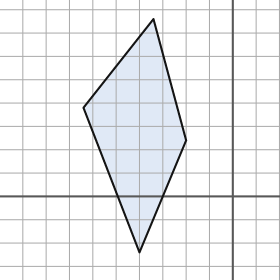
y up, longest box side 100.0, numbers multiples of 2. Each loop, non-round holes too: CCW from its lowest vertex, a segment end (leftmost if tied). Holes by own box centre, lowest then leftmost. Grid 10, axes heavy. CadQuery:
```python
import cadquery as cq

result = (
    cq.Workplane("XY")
    .moveTo(-40.0, -24.0)
    .lineTo(-20.0, 24.0)
    .lineTo(-34.0, 76.0)
    .lineTo(-64.0, 38.0)
    .close()
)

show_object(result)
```